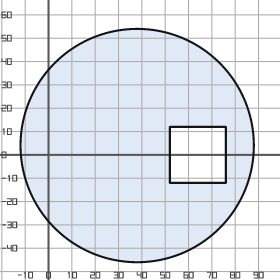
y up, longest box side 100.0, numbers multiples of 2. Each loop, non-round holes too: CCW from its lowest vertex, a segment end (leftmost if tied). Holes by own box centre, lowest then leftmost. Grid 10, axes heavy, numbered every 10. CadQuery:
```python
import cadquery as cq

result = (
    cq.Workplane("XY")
    .moveTo(38.0, 4.0)
    .circle(50.0)
    .moveTo(52.0, -12.0)
    .lineTo(76.0, -12.0)
    .lineTo(76.0, 12.0)
    .lineTo(52.0, 12.0)
    .close()
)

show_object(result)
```